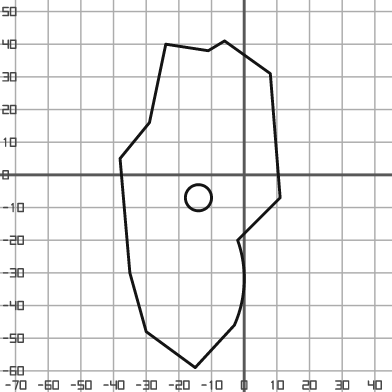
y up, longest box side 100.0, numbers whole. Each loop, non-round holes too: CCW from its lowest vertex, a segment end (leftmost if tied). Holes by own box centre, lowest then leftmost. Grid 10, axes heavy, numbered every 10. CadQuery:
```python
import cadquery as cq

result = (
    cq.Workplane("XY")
    .moveTo(-15.0, -59.0)
    .lineTo(-3.0, -46.0)
    .threePointArc((0.0, -33.0), (-2.0, -20.0))
    .lineTo(11.0, -7.0)
    .lineTo(8.0, 31.0)
    .lineTo(-6.0, 41.0)
    .lineTo(-11.0, 38.0)
    .lineTo(-24.0, 40.0)
    .lineTo(-29.0, 16.0)
    .lineTo(-38.0, 5.0)
    .lineTo(-35.0, -30.0)
    .lineTo(-30.0, -48.0)
    .close()
    .moveTo(-14.0, -7.0)
    .circle(4.0)
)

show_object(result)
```